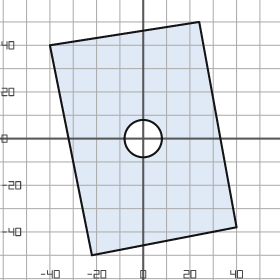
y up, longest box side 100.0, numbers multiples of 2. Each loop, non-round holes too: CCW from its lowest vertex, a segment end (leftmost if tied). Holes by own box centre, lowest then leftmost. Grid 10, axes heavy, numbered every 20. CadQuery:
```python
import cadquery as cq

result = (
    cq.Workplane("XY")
    .moveTo(-22.0, -50.0)
    .lineTo(40.0, -38.0)
    .lineTo(24.0, 50.0)
    .lineTo(-40.0, 40.0)
    .close()
    .moveTo(0.0, 0.0)
    .circle(8.0)
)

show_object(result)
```